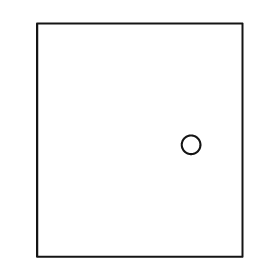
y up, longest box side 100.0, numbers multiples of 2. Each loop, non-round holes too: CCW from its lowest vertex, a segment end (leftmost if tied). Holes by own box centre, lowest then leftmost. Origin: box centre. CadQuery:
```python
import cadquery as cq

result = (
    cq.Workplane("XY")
    .moveTo(-44.0, -50.0)
    .lineTo(44.0, -50.0)
    .lineTo(44.0, 50.0)
    .lineTo(-44.0, 50.0)
    .close()
    .moveTo(22.0, -2.0)
    .circle(4.0)
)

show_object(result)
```